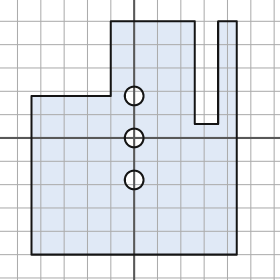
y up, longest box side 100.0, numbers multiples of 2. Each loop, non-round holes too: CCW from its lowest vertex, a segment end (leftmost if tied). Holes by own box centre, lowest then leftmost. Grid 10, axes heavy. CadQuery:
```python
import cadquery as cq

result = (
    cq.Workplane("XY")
    .moveTo(-44.0, -50.0)
    .lineTo(44.0, -50.0)
    .lineTo(44.0, 50.0)
    .lineTo(36.0, 50.0)
    .lineTo(36.0, 6.0)
    .lineTo(26.0, 6.0)
    .lineTo(26.0, 50.0)
    .lineTo(-10.0, 50.0)
    .lineTo(-10.0, 18.0)
    .lineTo(-44.0, 18.0)
    .close()
    .moveTo(0.0, -18.0)
    .circle(4.0)
    .moveTo(0.0, 0.0)
    .circle(4.0)
    .moveTo(0.0, 18.0)
    .circle(4.0)
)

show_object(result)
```